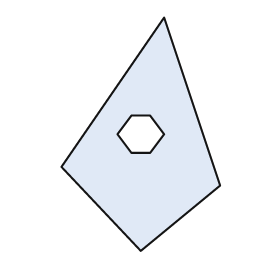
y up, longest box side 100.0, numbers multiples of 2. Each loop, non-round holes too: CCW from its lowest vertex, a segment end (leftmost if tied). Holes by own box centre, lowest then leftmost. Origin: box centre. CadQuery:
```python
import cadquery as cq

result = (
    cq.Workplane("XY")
    .moveTo(0.0, -50.0)
    .lineTo(34.0, -22.0)
    .lineTo(10.0, 50.0)
    .lineTo(-34.0, -14.0)
    .close()
    .moveTo(-4.0, -8.0)
    .lineTo(4.0, -8.0)
    .lineTo(10.0, 0.0)
    .lineTo(4.0, 8.0)
    .lineTo(-4.0, 8.0)
    .lineTo(-10.0, 0.0)
    .close()
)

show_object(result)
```